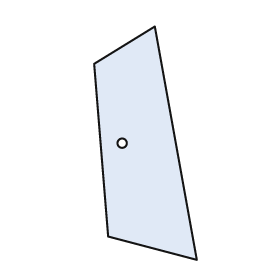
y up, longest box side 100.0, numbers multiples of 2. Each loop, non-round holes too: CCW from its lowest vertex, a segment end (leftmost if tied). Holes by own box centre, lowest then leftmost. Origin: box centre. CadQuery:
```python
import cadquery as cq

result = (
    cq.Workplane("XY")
    .moveTo(22.0, -50.0)
    .lineTo(4.0, 50.0)
    .lineTo(-22.0, 34.0)
    .lineTo(-16.0, -40.0)
    .close()
    .moveTo(-10.0, 0.0)
    .circle(2.0)
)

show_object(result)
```